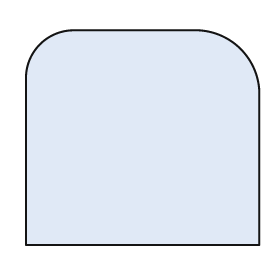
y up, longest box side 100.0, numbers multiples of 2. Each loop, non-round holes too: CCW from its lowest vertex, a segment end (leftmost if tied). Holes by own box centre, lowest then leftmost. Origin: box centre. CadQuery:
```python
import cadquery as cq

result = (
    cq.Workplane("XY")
    .moveTo(-50.0, -46.0)
    .lineTo(50.0, -46.0)
    .lineTo(50.0, 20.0)
    .threePointArc((42.0, 38.0), (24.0, 46.0))
    .lineTo(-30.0, 46.0)
    .threePointArc((-44.0, 40.0), (-50.0, 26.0))
    .close()
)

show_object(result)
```